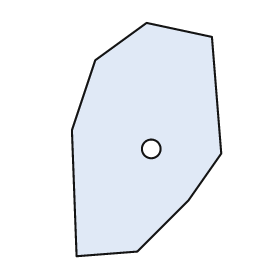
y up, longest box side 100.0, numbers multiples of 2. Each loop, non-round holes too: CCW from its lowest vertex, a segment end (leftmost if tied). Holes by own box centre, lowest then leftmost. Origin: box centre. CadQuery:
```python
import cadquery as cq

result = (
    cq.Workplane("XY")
    .moveTo(-30.0, -50.0)
    .lineTo(-4.0, -48.0)
    .lineTo(18.0, -26.0)
    .lineTo(32.0, -6.0)
    .lineTo(28.0, 44.0)
    .lineTo(0.0, 50.0)
    .lineTo(-22.0, 34.0)
    .lineTo(-32.0, 4.0)
    .close()
    .moveTo(2.0, -4.0)
    .circle(4.0)
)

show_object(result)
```